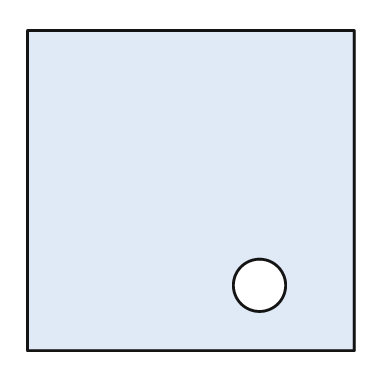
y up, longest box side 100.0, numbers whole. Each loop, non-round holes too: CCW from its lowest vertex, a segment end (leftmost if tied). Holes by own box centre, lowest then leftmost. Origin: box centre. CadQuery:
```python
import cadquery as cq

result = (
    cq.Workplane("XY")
    .moveTo(-50.0, -49.0)
    .lineTo(50.0, -49.0)
    .lineTo(50.0, 49.0)
    .lineTo(-50.0, 49.0)
    .close()
    .moveTo(21.0, -29.0)
    .circle(8.0)
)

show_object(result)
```